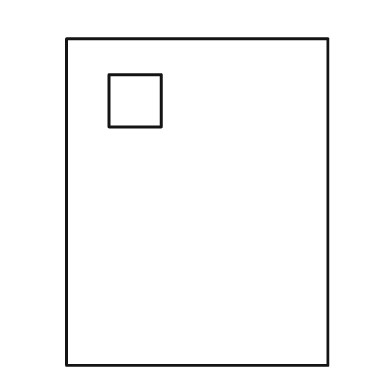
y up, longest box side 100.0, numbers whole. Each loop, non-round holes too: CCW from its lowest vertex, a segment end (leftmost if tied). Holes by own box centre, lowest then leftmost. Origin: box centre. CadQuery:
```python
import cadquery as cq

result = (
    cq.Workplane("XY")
    .moveTo(-40.0, -50.0)
    .lineTo(40.0, -50.0)
    .lineTo(40.0, 50.0)
    .lineTo(-40.0, 50.0)
    .close()
    .moveTo(-27.0, 23.0)
    .lineTo(-11.0, 23.0)
    .lineTo(-11.0, 39.0)
    .lineTo(-27.0, 39.0)
    .close()
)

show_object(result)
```